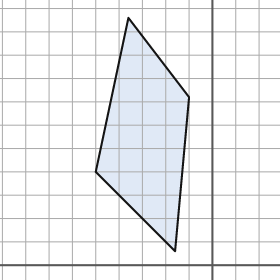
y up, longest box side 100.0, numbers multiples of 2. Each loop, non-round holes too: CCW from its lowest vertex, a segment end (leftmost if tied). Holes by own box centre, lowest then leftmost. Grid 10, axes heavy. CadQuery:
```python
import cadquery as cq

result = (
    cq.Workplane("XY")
    .moveTo(-16.0, 6.0)
    .lineTo(-10.0, 72.0)
    .lineTo(-36.0, 106.0)
    .lineTo(-50.0, 40.0)
    .close()
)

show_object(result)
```